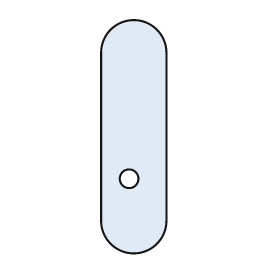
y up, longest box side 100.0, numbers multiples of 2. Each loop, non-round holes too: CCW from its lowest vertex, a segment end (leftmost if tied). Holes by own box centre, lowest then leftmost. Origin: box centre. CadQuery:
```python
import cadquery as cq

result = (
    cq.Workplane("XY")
    .moveTo(-14.0, -36.0)
    .threePointArc((0.0, -50.0), (14.0, -36.0))
    .lineTo(14.0, 36.0)
    .threePointArc((0.0, 50.0), (-14.0, 36.0))
    .close()
    .moveTo(-2.0, -18.0)
    .circle(4.0)
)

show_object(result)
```